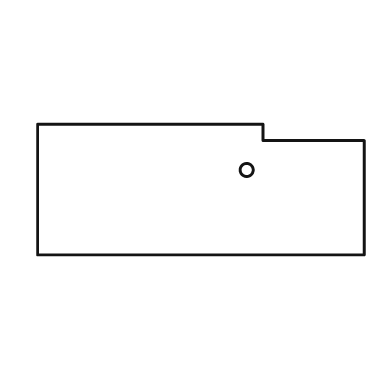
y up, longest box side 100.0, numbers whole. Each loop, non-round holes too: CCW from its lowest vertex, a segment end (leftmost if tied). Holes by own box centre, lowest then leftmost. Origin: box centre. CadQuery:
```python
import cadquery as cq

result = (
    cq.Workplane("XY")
    .moveTo(-50.0, -20.0)
    .lineTo(50.0, -20.0)
    .lineTo(50.0, 15.0)
    .lineTo(19.0, 15.0)
    .lineTo(19.0, 20.0)
    .lineTo(-50.0, 20.0)
    .close()
    .moveTo(14.0, 6.0)
    .circle(2.0)
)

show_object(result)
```